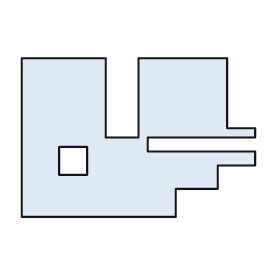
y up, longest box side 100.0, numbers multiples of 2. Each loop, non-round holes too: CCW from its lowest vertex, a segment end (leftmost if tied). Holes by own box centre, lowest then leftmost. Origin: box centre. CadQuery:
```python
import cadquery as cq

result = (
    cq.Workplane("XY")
    .moveTo(-50.0, -34.0)
    .lineTo(16.0, -34.0)
    .lineTo(16.0, -22.0)
    .lineTo(34.0, -22.0)
    .lineTo(34.0, -12.0)
    .lineTo(50.0, -12.0)
    .lineTo(50.0, -6.0)
    .lineTo(4.0, -6.0)
    .lineTo(4.0, 0.0)
    .lineTo(50.0, 0.0)
    .lineTo(50.0, 4.0)
    .lineTo(38.0, 4.0)
    .lineTo(38.0, 34.0)
    .lineTo(0.0, 34.0)
    .lineTo(0.0, 0.0)
    .lineTo(-14.0, 0.0)
    .lineTo(-14.0, 34.0)
    .lineTo(-50.0, 34.0)
    .close()
    .moveTo(-34.0, -16.0)
    .lineTo(-22.0, -16.0)
    .lineTo(-22.0, -4.0)
    .lineTo(-34.0, -4.0)
    .close()
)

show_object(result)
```